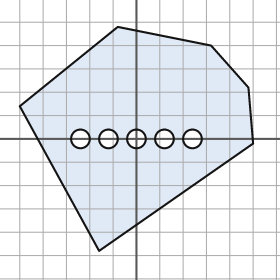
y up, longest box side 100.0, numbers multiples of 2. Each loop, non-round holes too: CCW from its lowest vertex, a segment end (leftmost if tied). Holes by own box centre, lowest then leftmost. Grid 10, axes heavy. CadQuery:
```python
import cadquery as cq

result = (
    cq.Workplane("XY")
    .moveTo(-16.0, -48.0)
    .lineTo(50.0, -2.0)
    .lineTo(48.0, 22.0)
    .lineTo(32.0, 40.0)
    .lineTo(-8.0, 48.0)
    .lineTo(-50.0, 14.0)
    .close()
    .moveTo(-24.0, 0.0)
    .circle(4.0)
    .moveTo(-12.0, 0.0)
    .circle(4.0)
    .moveTo(0.0, 0.0)
    .circle(4.0)
    .moveTo(12.0, 0.0)
    .circle(4.0)
    .moveTo(24.0, 0.0)
    .circle(4.0)
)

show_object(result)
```